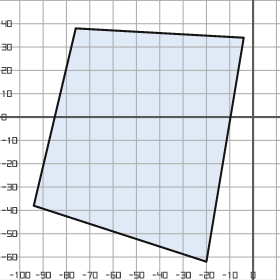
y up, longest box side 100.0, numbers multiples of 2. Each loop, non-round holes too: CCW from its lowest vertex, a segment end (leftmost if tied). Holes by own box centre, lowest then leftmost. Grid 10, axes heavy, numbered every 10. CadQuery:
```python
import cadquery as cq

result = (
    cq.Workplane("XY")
    .moveTo(-20.0, -62.0)
    .lineTo(-4.0, 34.0)
    .lineTo(-76.0, 38.0)
    .lineTo(-94.0, -38.0)
    .close()
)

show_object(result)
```